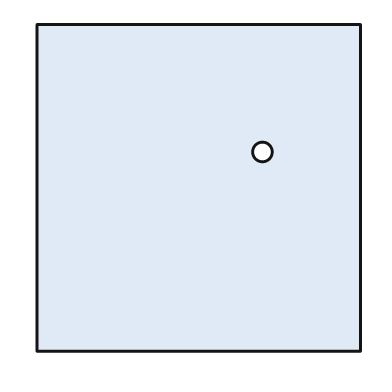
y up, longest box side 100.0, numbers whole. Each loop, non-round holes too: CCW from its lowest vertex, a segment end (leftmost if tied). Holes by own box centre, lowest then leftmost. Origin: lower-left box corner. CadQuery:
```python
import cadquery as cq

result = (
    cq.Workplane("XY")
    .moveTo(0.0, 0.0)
    .lineTo(99.0, 0.0)
    .lineTo(99.0, 100.0)
    .lineTo(0.0, 100.0)
    .close()
    .moveTo(69.0, 61.0)
    .circle(3.0)
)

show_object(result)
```